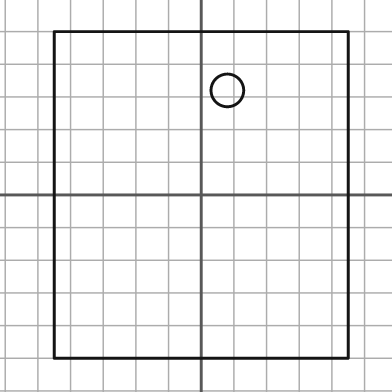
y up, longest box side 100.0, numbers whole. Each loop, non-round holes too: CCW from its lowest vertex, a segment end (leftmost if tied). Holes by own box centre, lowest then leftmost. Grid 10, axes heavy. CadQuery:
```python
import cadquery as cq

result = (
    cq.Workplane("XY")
    .moveTo(-45.0, -50.0)
    .lineTo(45.0, -50.0)
    .lineTo(45.0, 50.0)
    .lineTo(-45.0, 50.0)
    .close()
    .moveTo(8.0, 32.0)
    .circle(5.0)
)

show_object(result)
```